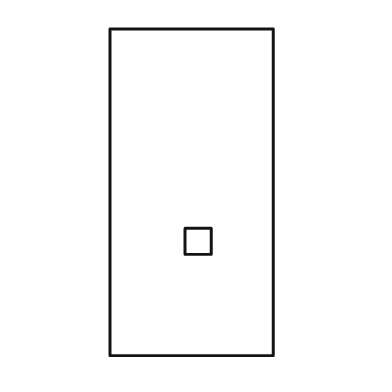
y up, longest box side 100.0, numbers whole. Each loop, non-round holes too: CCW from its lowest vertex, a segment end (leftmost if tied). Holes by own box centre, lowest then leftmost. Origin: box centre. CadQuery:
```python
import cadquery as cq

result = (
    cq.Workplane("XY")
    .moveTo(-25.0, -50.0)
    .lineTo(25.0, -50.0)
    .lineTo(25.0, 50.0)
    .lineTo(-25.0, 50.0)
    .close()
    .moveTo(-2.0, -19.0)
    .lineTo(6.0, -19.0)
    .lineTo(6.0, -11.0)
    .lineTo(-2.0, -11.0)
    .close()
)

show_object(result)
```